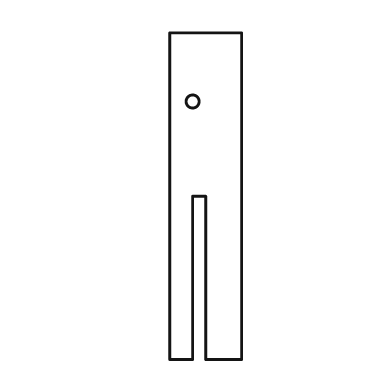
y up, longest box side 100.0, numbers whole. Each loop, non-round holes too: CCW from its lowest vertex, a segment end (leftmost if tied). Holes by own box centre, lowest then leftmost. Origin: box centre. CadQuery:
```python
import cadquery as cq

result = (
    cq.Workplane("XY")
    .moveTo(-11.0, -50.0)
    .lineTo(-4.0, -50.0)
    .lineTo(-4.0, 0.0)
    .lineTo(0.0, 0.0)
    .lineTo(0.0, -50.0)
    .lineTo(11.0, -50.0)
    .lineTo(11.0, 50.0)
    .lineTo(-11.0, 50.0)
    .close()
    .moveTo(-4.0, 29.0)
    .circle(2.0)
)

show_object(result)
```